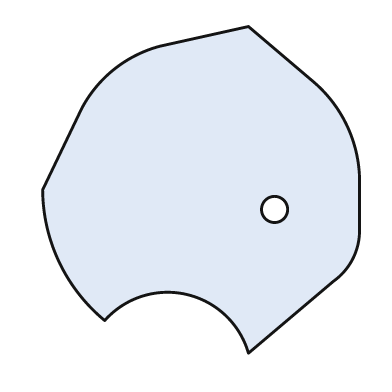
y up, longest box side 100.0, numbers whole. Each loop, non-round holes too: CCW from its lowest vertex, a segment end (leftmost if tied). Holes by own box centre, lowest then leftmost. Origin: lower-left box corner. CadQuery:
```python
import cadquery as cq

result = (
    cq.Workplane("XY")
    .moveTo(63.0, 0.0)
    .lineTo(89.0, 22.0)
    .threePointArc((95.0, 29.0), (97.0, 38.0))
    .lineTo(97.0, 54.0)
    .threePointArc((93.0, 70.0), (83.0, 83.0))
    .lineTo(63.0, 100.0)
    .lineTo(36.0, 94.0)
    .threePointArc((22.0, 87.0), (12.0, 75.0))
    .lineTo(0.0, 50.0)
    .threePointArc((5.0, 28.0), (19.0, 10.0))
    .threePointArc((44.0, 18.0), (63.0, 0.0))
    .close()
    .moveTo(71.0, 44.0)
    .circle(4.0)
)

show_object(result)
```